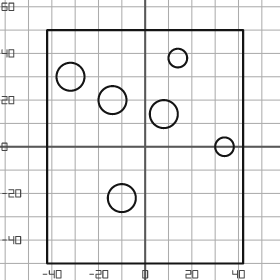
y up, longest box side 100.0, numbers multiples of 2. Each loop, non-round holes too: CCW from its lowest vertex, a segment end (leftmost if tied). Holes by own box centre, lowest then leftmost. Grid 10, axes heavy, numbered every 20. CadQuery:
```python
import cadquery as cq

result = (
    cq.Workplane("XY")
    .moveTo(-42.0, -50.0)
    .lineTo(42.0, -50.0)
    .lineTo(42.0, 50.0)
    .lineTo(-42.0, 50.0)
    .close()
    .moveTo(-10.0, -22.0)
    .circle(6.0)
    .moveTo(34.0, 0.0)
    .circle(4.0)
    .moveTo(8.0, 14.0)
    .circle(6.0)
    .moveTo(-14.0, 20.0)
    .circle(6.0)
    .moveTo(-32.0, 30.0)
    .circle(6.0)
    .moveTo(14.0, 38.0)
    .circle(4.0)
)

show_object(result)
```